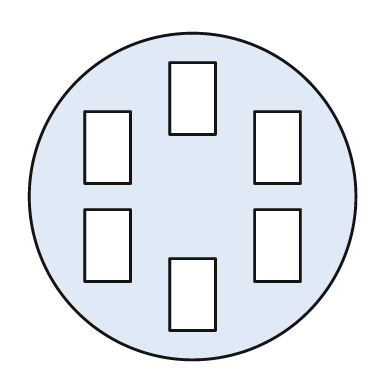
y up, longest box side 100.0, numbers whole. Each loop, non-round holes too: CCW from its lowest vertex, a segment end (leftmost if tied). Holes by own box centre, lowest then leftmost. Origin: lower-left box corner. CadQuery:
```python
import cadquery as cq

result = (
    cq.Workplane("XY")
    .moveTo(50.0, 50.0)
    .circle(50.0)
    .moveTo(43.0, 9.0)
    .lineTo(57.0, 9.0)
    .lineTo(57.0, 31.0)
    .lineTo(43.0, 31.0)
    .close()
    .moveTo(17.0, 24.0)
    .lineTo(31.0, 24.0)
    .lineTo(31.0, 46.0)
    .lineTo(17.0, 46.0)
    .close()
    .moveTo(69.0, 24.0)
    .lineTo(83.0, 24.0)
    .lineTo(83.0, 46.0)
    .lineTo(69.0, 46.0)
    .close()
    .moveTo(17.0, 54.0)
    .lineTo(31.0, 54.0)
    .lineTo(31.0, 76.0)
    .lineTo(17.0, 76.0)
    .close()
    .moveTo(69.0, 54.0)
    .lineTo(83.0, 54.0)
    .lineTo(83.0, 76.0)
    .lineTo(69.0, 76.0)
    .close()
    .moveTo(43.0, 69.0)
    .lineTo(57.0, 69.0)
    .lineTo(57.0, 91.0)
    .lineTo(43.0, 91.0)
    .close()
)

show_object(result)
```